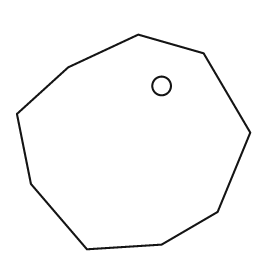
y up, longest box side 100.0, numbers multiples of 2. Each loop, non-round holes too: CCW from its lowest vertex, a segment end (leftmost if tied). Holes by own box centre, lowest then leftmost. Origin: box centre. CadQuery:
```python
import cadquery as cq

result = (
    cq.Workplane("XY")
    .moveTo(-20.0, -46.0)
    .lineTo(12.0, -44.0)
    .lineTo(36.0, -30.0)
    .lineTo(50.0, 4.0)
    .lineTo(30.0, 38.0)
    .lineTo(2.0, 46.0)
    .lineTo(-28.0, 32.0)
    .lineTo(-50.0, 12.0)
    .lineTo(-44.0, -18.0)
    .close()
    .moveTo(12.0, 24.0)
    .circle(4.0)
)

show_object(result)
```